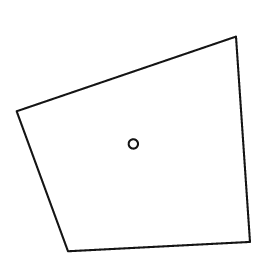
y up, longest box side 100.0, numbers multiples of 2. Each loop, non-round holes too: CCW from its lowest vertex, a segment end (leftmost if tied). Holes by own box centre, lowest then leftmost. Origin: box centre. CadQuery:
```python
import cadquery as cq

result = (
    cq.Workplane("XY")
    .moveTo(-28.0, -46.0)
    .lineTo(50.0, -42.0)
    .lineTo(44.0, 46.0)
    .lineTo(-50.0, 14.0)
    .close()
    .moveTo(0.0, 0.0)
    .circle(2.0)
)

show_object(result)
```